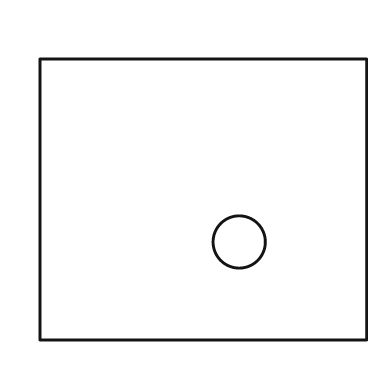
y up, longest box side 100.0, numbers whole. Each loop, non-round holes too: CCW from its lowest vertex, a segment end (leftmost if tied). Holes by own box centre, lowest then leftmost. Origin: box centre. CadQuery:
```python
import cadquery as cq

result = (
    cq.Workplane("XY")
    .moveTo(-50.0, -43.0)
    .lineTo(50.0, -43.0)
    .lineTo(50.0, 43.0)
    .lineTo(-50.0, 43.0)
    .close()
    .moveTo(11.0, -13.0)
    .circle(8.0)
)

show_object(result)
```